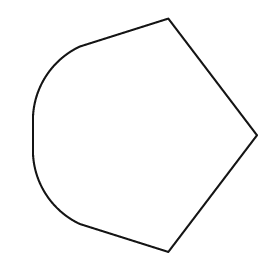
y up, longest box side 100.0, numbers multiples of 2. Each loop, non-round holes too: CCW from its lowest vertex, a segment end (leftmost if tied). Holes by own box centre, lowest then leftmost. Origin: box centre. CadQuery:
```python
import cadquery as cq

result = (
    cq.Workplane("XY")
    .moveTo(10.0, -50.0)
    .lineTo(48.0, 0.0)
    .lineTo(10.0, 50.0)
    .lineTo(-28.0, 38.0)
    .threePointArc((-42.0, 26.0), (-48.0, 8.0))
    .lineTo(-48.0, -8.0)
    .threePointArc((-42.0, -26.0), (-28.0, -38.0))
    .close()
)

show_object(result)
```